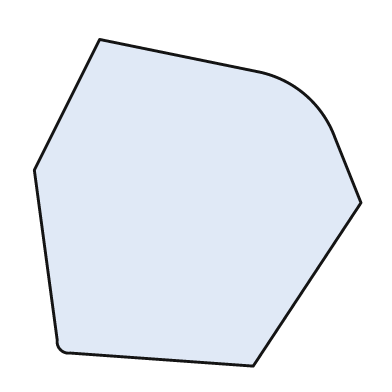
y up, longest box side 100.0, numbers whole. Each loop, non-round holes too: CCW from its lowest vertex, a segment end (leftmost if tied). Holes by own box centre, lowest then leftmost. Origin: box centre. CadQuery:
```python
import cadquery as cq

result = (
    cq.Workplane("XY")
    .moveTo(17.0, -50.0)
    .lineTo(50.0, 0.0)
    .lineTo(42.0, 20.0)
    .threePointArc((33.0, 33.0), (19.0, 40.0))
    .lineTo(-30.0, 50.0)
    .lineTo(-50.0, 10.0)
    .lineTo(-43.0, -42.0)
    .threePointArc((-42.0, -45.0), (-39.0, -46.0))
    .close()
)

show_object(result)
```